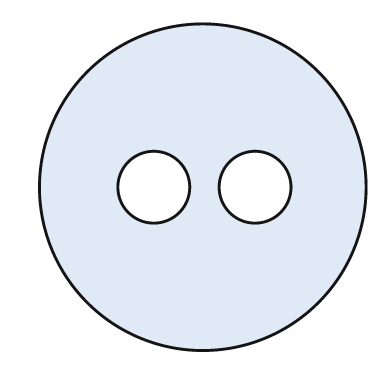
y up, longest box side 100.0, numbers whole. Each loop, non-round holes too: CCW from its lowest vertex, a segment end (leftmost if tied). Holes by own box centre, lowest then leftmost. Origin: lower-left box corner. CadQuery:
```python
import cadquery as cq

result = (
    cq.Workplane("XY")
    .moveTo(50.0, 50.0)
    .circle(50.0)
    .moveTo(35.0, 50.0)
    .circle(11.0)
    .moveTo(66.0, 50.0)
    .circle(11.0)
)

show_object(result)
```